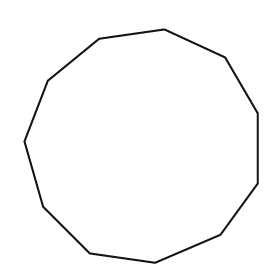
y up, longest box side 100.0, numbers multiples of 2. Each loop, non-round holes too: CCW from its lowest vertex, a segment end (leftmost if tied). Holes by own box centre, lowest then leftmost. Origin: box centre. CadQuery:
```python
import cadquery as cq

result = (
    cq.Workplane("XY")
    .moveTo(6.0, -50.0)
    .lineTo(34.0, -38.0)
    .lineTo(50.0, -16.0)
    .lineTo(50.0, 14.0)
    .lineTo(36.0, 38.0)
    .lineTo(10.0, 50.0)
    .lineTo(-18.0, 46.0)
    .lineTo(-40.0, 28.0)
    .lineTo(-50.0, 2.0)
    .lineTo(-42.0, -26.0)
    .lineTo(-22.0, -46.0)
    .close()
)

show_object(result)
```